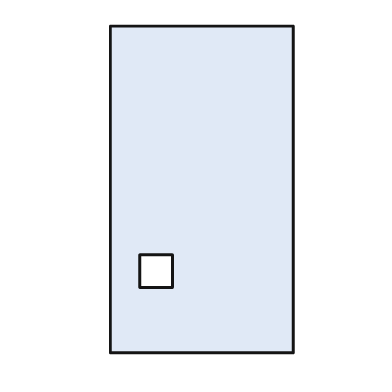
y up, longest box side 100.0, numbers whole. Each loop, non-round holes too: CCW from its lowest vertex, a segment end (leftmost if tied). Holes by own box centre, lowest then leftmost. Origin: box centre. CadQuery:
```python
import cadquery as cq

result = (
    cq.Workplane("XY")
    .moveTo(-28.0, -50.0)
    .lineTo(28.0, -50.0)
    .lineTo(28.0, 50.0)
    .lineTo(-28.0, 50.0)
    .close()
    .moveTo(-19.0, -30.0)
    .lineTo(-9.0, -30.0)
    .lineTo(-9.0, -20.0)
    .lineTo(-19.0, -20.0)
    .close()
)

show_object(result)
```